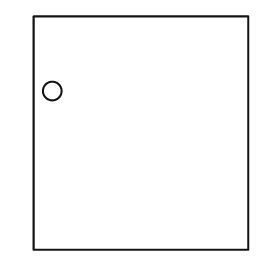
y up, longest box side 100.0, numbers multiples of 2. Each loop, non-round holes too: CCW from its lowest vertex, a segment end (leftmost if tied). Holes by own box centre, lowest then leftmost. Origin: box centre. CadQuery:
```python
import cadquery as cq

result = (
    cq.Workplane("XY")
    .moveTo(-46.0, -50.0)
    .lineTo(46.0, -50.0)
    .lineTo(46.0, 50.0)
    .lineTo(-46.0, 50.0)
    .close()
    .moveTo(-38.0, 18.0)
    .circle(4.0)
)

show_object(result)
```